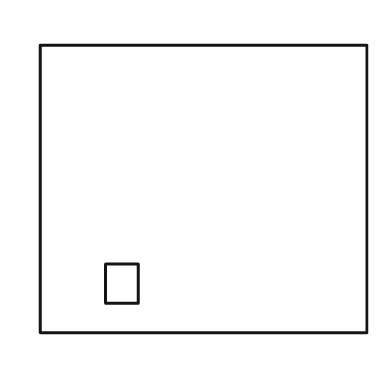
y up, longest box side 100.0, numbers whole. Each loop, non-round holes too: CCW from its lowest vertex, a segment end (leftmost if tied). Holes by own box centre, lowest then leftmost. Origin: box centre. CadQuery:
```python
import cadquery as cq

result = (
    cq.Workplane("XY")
    .moveTo(-50.0, -44.0)
    .lineTo(50.0, -44.0)
    .lineTo(50.0, 44.0)
    .lineTo(-50.0, 44.0)
    .close()
    .moveTo(-30.0, -35.0)
    .lineTo(-20.0, -35.0)
    .lineTo(-20.0, -23.0)
    .lineTo(-30.0, -23.0)
    .close()
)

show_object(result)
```